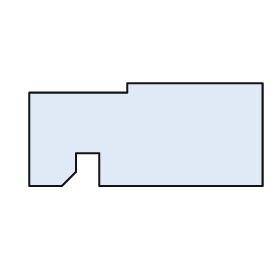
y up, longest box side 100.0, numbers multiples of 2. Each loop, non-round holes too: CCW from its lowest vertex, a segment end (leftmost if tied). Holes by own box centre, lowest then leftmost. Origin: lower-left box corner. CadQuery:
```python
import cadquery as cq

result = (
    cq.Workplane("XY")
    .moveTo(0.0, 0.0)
    .lineTo(14.0, 0.0)
    .lineTo(20.0, 6.0)
    .lineTo(20.0, 14.0)
    .lineTo(30.0, 14.0)
    .lineTo(30.0, 0.0)
    .lineTo(100.0, 0.0)
    .lineTo(100.0, 44.0)
    .lineTo(42.0, 44.0)
    .lineTo(42.0, 40.0)
    .lineTo(0.0, 40.0)
    .close()
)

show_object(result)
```